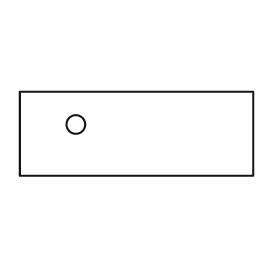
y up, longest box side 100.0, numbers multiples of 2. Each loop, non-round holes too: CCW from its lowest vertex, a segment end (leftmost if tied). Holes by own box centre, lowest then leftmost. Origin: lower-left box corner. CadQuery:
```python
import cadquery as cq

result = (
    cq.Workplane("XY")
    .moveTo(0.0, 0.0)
    .lineTo(100.0, 0.0)
    .lineTo(100.0, 36.0)
    .lineTo(0.0, 36.0)
    .close()
    .moveTo(24.0, 22.0)
    .circle(4.0)
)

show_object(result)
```